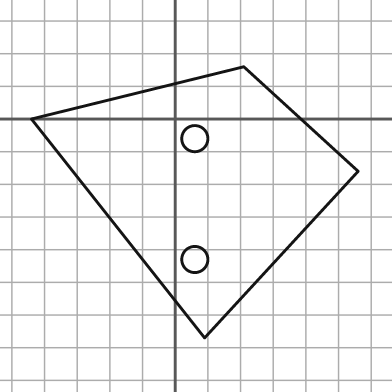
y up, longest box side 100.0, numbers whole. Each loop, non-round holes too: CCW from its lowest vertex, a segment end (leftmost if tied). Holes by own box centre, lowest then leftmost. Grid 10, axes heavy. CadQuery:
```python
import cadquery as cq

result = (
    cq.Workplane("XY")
    .moveTo(9.0, -67.0)
    .lineTo(56.0, -16.0)
    .lineTo(21.0, 16.0)
    .lineTo(-44.0, 0.0)
    .close()
    .moveTo(6.0, -43.0)
    .circle(4.0)
    .moveTo(6.0, -6.0)
    .circle(4.0)
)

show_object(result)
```